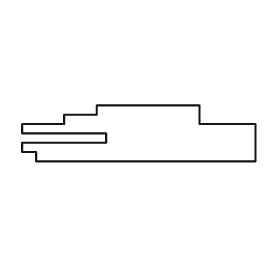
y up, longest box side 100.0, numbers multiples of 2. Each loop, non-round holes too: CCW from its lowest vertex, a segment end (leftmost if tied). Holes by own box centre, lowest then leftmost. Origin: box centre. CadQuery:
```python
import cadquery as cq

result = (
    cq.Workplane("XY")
    .moveTo(-44.0, -12.0)
    .lineTo(50.0, -12.0)
    .lineTo(50.0, 4.0)
    .lineTo(26.0, 4.0)
    .lineTo(26.0, 12.0)
    .lineTo(-18.0, 12.0)
    .lineTo(-18.0, 8.0)
    .lineTo(-32.0, 8.0)
    .lineTo(-32.0, 4.0)
    .lineTo(-50.0, 4.0)
    .lineTo(-50.0, 0.0)
    .lineTo(-14.0, 0.0)
    .lineTo(-14.0, -4.0)
    .lineTo(-50.0, -4.0)
    .lineTo(-50.0, -8.0)
    .lineTo(-44.0, -8.0)
    .close()
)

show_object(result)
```